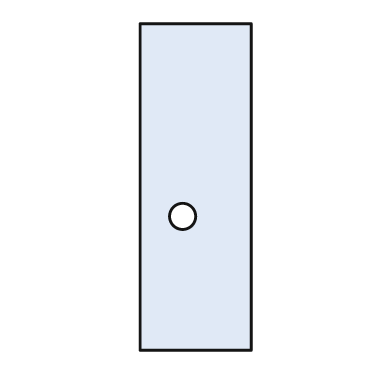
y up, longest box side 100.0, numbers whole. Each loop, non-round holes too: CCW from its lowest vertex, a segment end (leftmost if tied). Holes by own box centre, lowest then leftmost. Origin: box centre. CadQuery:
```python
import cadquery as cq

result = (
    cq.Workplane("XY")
    .moveTo(-17.0, -50.0)
    .lineTo(17.0, -50.0)
    .lineTo(17.0, 50.0)
    .lineTo(-17.0, 50.0)
    .close()
    .moveTo(-4.0, -9.0)
    .circle(4.0)
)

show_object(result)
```